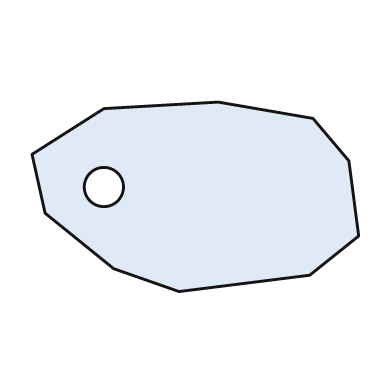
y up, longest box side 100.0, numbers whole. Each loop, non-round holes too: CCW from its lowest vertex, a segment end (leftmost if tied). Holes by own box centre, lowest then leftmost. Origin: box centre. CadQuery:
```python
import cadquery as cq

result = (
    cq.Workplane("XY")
    .moveTo(-5.0, -29.0)
    .lineTo(35.0, -24.0)
    .lineTo(50.0, -12.0)
    .lineTo(47.0, 11.0)
    .lineTo(36.0, 24.0)
    .lineTo(7.0, 29.0)
    .lineTo(-28.0, 27.0)
    .lineTo(-50.0, 13.0)
    .lineTo(-46.0, -5.0)
    .lineTo(-25.0, -22.0)
    .close()
    .moveTo(-28.0, 3.0)
    .circle(6.0)
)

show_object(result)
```